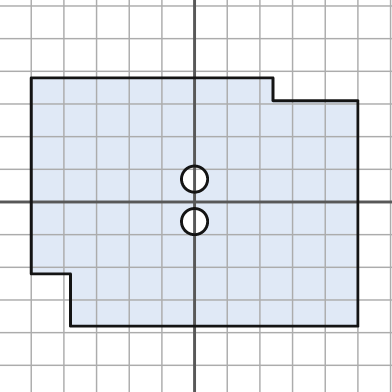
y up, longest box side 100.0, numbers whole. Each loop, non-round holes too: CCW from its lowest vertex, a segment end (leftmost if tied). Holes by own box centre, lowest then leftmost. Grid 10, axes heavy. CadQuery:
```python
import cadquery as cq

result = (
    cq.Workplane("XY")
    .moveTo(-38.0, -38.0)
    .lineTo(50.0, -38.0)
    .lineTo(50.0, 31.0)
    .lineTo(24.0, 31.0)
    .lineTo(24.0, 38.0)
    .lineTo(-50.0, 38.0)
    .lineTo(-50.0, -22.0)
    .lineTo(-38.0, -22.0)
    .close()
    .moveTo(0.0, -6.0)
    .circle(4.0)
    .moveTo(0.0, 7.0)
    .circle(4.0)
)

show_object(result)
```